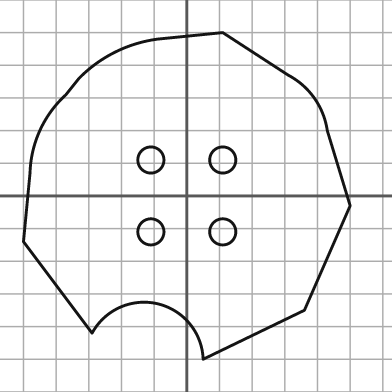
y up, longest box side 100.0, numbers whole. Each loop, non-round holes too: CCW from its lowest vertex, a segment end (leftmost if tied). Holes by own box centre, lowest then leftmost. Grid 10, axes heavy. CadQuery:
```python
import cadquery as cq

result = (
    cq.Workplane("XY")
    .moveTo(5.0, -50.0)
    .lineTo(36.0, -35.0)
    .lineTo(50.0, -3.0)
    .lineTo(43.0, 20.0)
    .threePointArc((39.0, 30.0), (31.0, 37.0))
    .lineTo(11.0, 50.0)
    .lineTo(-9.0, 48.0)
    .threePointArc((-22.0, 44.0), (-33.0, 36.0))
    .lineTo(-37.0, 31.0)
    .threePointArc((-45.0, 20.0), (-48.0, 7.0))
    .lineTo(-50.0, -14.0)
    .lineTo(-29.0, -42.0)
    .threePointArc((-9.0, -33.0), (5.0, -50.0))
    .close()
    .moveTo(-11.0, -11.0)
    .circle(4.0)
    .moveTo(11.0, -11.0)
    .circle(4.0)
    .moveTo(-11.0, 11.0)
    .circle(4.0)
    .moveTo(11.0, 11.0)
    .circle(4.0)
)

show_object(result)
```